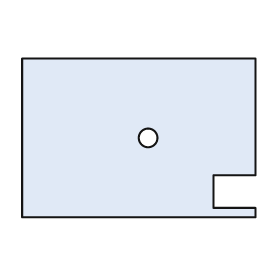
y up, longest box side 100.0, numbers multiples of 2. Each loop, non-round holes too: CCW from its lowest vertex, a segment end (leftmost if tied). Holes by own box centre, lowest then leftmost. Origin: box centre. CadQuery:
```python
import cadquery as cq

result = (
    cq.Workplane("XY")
    .moveTo(-50.0, -34.0)
    .lineTo(50.0, -34.0)
    .lineTo(50.0, -30.0)
    .lineTo(32.0, -30.0)
    .lineTo(32.0, -16.0)
    .lineTo(50.0, -16.0)
    .lineTo(50.0, 34.0)
    .lineTo(-50.0, 34.0)
    .close()
    .moveTo(4.0, 0.0)
    .circle(4.0)
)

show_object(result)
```